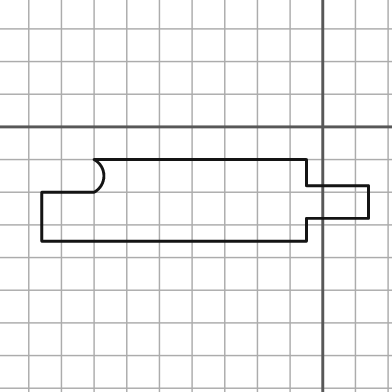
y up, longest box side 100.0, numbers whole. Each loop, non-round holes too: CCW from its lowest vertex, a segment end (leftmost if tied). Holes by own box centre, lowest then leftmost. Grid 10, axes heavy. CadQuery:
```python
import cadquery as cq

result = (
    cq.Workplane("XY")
    .moveTo(-86.0, -35.0)
    .lineTo(-5.0, -35.0)
    .lineTo(-5.0, -28.0)
    .lineTo(14.0, -28.0)
    .lineTo(14.0, -18.0)
    .lineTo(-5.0, -18.0)
    .lineTo(-5.0, -10.0)
    .lineTo(-70.0, -10.0)
    .threePointArc((-67.0, -15.0), (-70.0, -20.0))
    .lineTo(-86.0, -20.0)
    .close()
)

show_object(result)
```